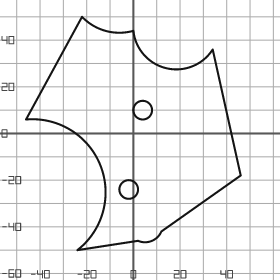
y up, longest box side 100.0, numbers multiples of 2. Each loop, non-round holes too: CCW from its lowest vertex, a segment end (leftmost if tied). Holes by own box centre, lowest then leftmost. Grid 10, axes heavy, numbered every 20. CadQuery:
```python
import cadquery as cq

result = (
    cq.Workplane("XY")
    .moveTo(-24.0, -50.0)
    .lineTo(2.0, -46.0)
    .threePointArc((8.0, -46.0), (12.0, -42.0))
    .lineTo(46.0, -18.0)
    .lineTo(34.0, 36.0)
    .threePointArc((14.0, 28.0), (0.0, 44.0))
    .threePointArc((-12.0, 44.0), (-22.0, 50.0))
    .lineTo(-46.0, 6.0)
    .threePointArc((-14.0, -14.0), (-24.0, -50.0))
    .close()
    .moveTo(-2.0, -24.0)
    .circle(4.0)
    .moveTo(4.0, 10.0)
    .circle(4.0)
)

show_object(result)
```